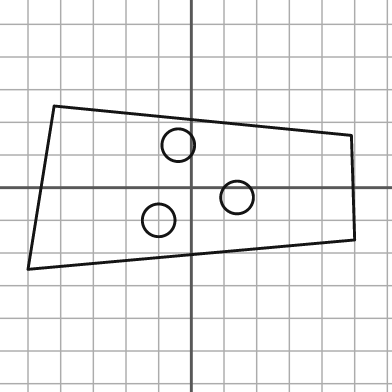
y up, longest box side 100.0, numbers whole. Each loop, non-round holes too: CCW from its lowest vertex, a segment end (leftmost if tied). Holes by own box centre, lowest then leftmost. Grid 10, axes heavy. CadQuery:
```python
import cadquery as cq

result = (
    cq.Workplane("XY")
    .moveTo(-50.0, -25.0)
    .lineTo(50.0, -16.0)
    .lineTo(49.0, 16.0)
    .lineTo(-42.0, 25.0)
    .close()
    .moveTo(-10.0, -10.0)
    .circle(5.0)
    .moveTo(14.0, -3.0)
    .circle(5.0)
    .moveTo(-4.0, 13.0)
    .circle(5.0)
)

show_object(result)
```